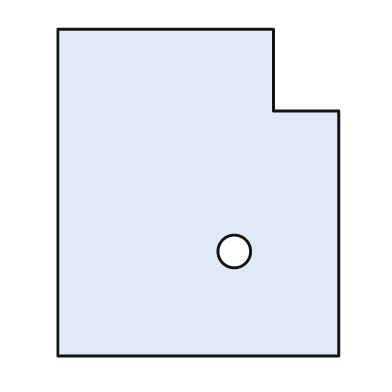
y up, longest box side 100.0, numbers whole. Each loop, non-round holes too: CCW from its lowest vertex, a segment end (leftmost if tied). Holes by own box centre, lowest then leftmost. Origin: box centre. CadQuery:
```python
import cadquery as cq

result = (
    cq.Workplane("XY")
    .moveTo(-43.0, -50.0)
    .lineTo(43.0, -50.0)
    .lineTo(43.0, 25.0)
    .lineTo(23.0, 25.0)
    .lineTo(23.0, 50.0)
    .lineTo(-43.0, 50.0)
    .close()
    .moveTo(11.0, -18.0)
    .circle(5.0)
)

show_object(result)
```